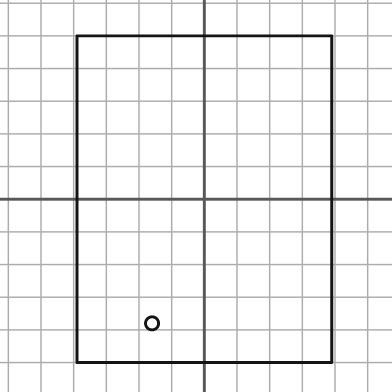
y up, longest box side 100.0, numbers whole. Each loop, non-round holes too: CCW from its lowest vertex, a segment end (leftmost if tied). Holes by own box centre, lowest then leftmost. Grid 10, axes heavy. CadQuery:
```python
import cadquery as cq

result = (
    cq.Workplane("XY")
    .moveTo(-39.0, -50.0)
    .lineTo(39.0, -50.0)
    .lineTo(39.0, 50.0)
    .lineTo(-39.0, 50.0)
    .close()
    .moveTo(-16.0, -38.0)
    .circle(2.0)
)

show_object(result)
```